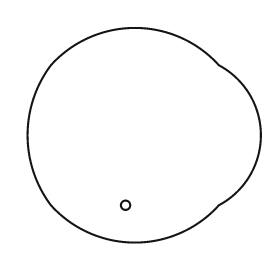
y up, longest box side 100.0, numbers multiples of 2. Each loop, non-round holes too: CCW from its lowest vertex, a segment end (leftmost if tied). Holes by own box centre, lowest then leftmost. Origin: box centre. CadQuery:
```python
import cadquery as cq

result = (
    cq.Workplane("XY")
    .moveTo(-40.0, -30.0)
    .threePointArc((-4.0, -46.0), (32.0, -30.0))
    .threePointArc((50.0, 0.0), (32.0, 30.0))
    .threePointArc((-4.0, 46.0), (-40.0, 30.0))
    .threePointArc((-50.0, 0.0), (-40.0, -30.0))
    .close()
    .moveTo(-8.0, -30.0)
    .circle(2.0)
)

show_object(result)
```